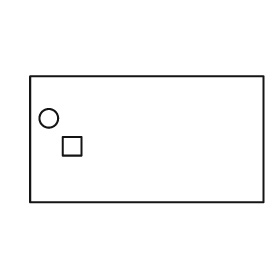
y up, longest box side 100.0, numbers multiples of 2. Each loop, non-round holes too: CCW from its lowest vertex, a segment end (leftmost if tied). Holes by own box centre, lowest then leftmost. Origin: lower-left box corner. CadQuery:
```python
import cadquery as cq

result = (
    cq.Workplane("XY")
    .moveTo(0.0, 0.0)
    .lineTo(100.0, 0.0)
    .lineTo(100.0, 54.0)
    .lineTo(0.0, 54.0)
    .close()
    .moveTo(14.0, 20.0)
    .lineTo(22.0, 20.0)
    .lineTo(22.0, 28.0)
    .lineTo(14.0, 28.0)
    .close()
    .moveTo(8.0, 36.0)
    .circle(4.0)
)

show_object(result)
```